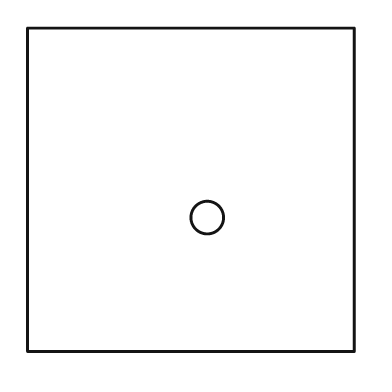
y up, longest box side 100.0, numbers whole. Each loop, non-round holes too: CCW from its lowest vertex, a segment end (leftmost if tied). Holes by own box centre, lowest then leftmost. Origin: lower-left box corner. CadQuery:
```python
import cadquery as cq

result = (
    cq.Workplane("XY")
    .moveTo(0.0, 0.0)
    .lineTo(100.0, 0.0)
    .lineTo(100.0, 99.0)
    .lineTo(0.0, 99.0)
    .close()
    .moveTo(55.0, 41.0)
    .circle(5.0)
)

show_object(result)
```